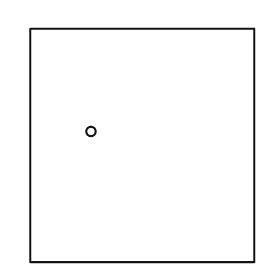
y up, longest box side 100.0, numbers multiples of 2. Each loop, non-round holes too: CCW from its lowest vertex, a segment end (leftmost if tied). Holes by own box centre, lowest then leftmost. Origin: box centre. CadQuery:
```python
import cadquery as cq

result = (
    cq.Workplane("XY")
    .moveTo(-48.0, -50.0)
    .lineTo(48.0, -50.0)
    .lineTo(48.0, 50.0)
    .lineTo(-48.0, 50.0)
    .close()
    .moveTo(-22.0, 6.0)
    .circle(2.0)
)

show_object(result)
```